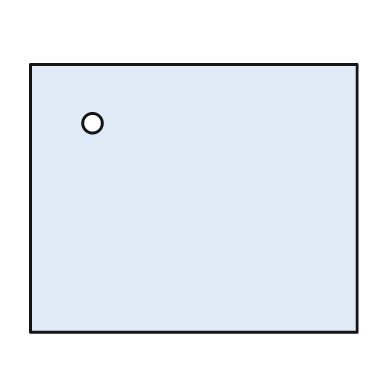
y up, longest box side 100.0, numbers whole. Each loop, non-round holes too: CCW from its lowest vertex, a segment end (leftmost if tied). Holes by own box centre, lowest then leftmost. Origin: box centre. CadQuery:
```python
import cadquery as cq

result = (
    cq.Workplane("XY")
    .moveTo(-50.0, -41.0)
    .lineTo(50.0, -41.0)
    .lineTo(50.0, 41.0)
    .lineTo(-50.0, 41.0)
    .close()
    .moveTo(-31.0, 23.0)
    .circle(3.0)
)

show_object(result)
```